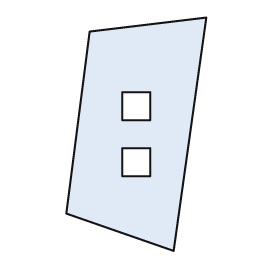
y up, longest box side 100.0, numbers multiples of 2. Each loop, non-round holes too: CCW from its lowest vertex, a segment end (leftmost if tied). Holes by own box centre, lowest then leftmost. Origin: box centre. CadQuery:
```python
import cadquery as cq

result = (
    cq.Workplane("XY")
    .moveTo(16.0, -50.0)
    .lineTo(30.0, 50.0)
    .lineTo(-20.0, 44.0)
    .lineTo(-30.0, -34.0)
    .close()
    .moveTo(-6.0, -18.0)
    .lineTo(6.0, -18.0)
    .lineTo(6.0, -6.0)
    .lineTo(-6.0, -6.0)
    .close()
    .moveTo(-6.0, 6.0)
    .lineTo(6.0, 6.0)
    .lineTo(6.0, 18.0)
    .lineTo(-6.0, 18.0)
    .close()
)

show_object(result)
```